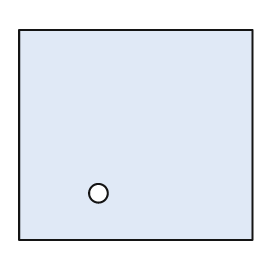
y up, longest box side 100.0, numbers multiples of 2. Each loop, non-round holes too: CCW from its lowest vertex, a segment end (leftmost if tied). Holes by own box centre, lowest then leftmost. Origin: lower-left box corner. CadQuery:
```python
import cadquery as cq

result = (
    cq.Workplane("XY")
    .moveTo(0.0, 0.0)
    .lineTo(100.0, 0.0)
    .lineTo(100.0, 90.0)
    .lineTo(0.0, 90.0)
    .close()
    .moveTo(34.0, 20.0)
    .circle(4.0)
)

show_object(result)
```